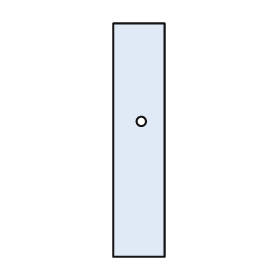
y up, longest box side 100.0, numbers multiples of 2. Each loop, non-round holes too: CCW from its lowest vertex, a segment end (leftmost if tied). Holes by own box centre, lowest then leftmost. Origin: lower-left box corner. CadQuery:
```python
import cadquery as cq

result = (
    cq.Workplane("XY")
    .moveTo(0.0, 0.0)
    .lineTo(22.0, 0.0)
    .lineTo(22.0, 100.0)
    .lineTo(0.0, 100.0)
    .close()
    .moveTo(12.0, 58.0)
    .circle(2.0)
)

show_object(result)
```